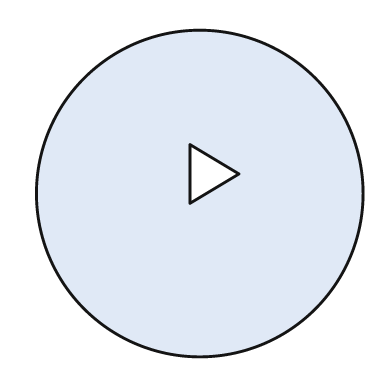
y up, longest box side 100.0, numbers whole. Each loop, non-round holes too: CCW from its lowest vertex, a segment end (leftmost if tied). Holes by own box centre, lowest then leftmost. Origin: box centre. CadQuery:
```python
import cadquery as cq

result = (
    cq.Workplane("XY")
    .moveTo(0.0, 0.0)
    .circle(50.0)
    .moveTo(-3.0, -3.0)
    .lineTo(12.0, 6.0)
    .lineTo(-3.0, 15.0)
    .close()
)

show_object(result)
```